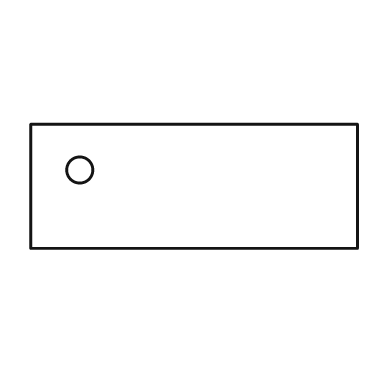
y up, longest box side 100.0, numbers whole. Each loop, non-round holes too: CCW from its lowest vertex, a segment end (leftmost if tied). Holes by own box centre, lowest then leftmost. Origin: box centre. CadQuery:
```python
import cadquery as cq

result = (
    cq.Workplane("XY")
    .moveTo(-50.0, -19.0)
    .lineTo(50.0, -19.0)
    .lineTo(50.0, 19.0)
    .lineTo(-50.0, 19.0)
    .close()
    .moveTo(-35.0, 5.0)
    .circle(4.0)
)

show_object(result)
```